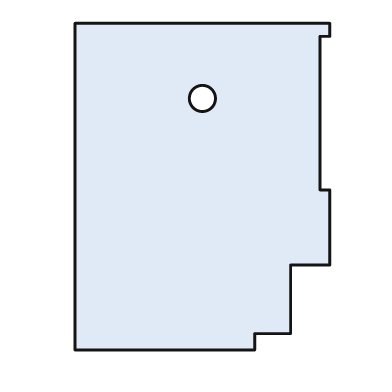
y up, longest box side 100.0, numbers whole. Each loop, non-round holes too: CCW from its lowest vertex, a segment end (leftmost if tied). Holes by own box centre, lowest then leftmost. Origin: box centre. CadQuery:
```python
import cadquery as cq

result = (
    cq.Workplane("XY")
    .moveTo(-39.0, -50.0)
    .lineTo(16.0, -50.0)
    .lineTo(16.0, -45.0)
    .lineTo(27.0, -45.0)
    .lineTo(27.0, -24.0)
    .lineTo(39.0, -24.0)
    .lineTo(39.0, -1.0)
    .lineTo(36.0, -1.0)
    .lineTo(36.0, 46.0)
    .lineTo(39.0, 46.0)
    .lineTo(39.0, 50.0)
    .lineTo(-39.0, 50.0)
    .close()
    .moveTo(0.0, 27.0)
    .circle(4.0)
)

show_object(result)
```